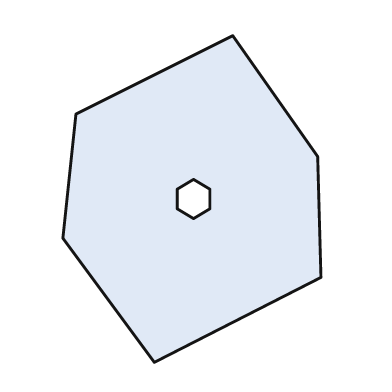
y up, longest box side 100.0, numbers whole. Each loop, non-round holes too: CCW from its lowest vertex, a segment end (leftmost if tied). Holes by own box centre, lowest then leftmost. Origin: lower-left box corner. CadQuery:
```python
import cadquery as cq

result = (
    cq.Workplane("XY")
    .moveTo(28.0, 0.0)
    .lineTo(79.0, 26.0)
    .lineTo(78.0, 63.0)
    .lineTo(52.0, 100.0)
    .lineTo(4.0, 76.0)
    .lineTo(0.0, 38.0)
    .close()
    .moveTo(40.0, 44.0)
    .lineTo(45.0, 47.0)
    .lineTo(45.0, 53.0)
    .lineTo(40.0, 56.0)
    .lineTo(35.0, 53.0)
    .lineTo(35.0, 47.0)
    .close()
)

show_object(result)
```